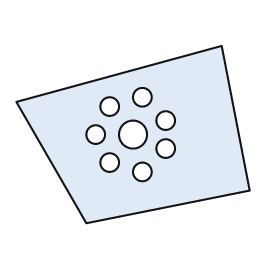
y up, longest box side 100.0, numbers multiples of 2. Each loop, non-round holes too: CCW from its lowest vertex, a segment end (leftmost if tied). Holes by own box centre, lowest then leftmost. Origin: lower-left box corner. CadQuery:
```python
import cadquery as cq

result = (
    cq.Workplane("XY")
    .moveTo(30.0, 0.0)
    .lineTo(100.0, 14.0)
    .lineTo(88.0, 76.0)
    .lineTo(0.0, 52.0)
    .close()
    .moveTo(54.0, 22.0)
    .circle(4.0)
    .moveTo(40.0, 26.0)
    .circle(4.0)
    .moveTo(64.0, 32.0)
    .circle(4.0)
    .moveTo(34.0, 38.0)
    .circle(4.0)
    .moveTo(50.0, 38.0)
    .circle(6.0)
    .moveTo(64.0, 44.0)
    .circle(4.0)
    .moveTo(40.0, 50.0)
    .circle(4.0)
    .moveTo(54.0, 54.0)
    .circle(4.0)
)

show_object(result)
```